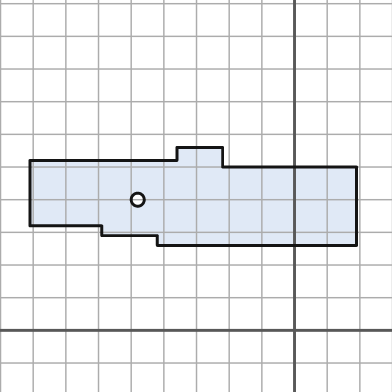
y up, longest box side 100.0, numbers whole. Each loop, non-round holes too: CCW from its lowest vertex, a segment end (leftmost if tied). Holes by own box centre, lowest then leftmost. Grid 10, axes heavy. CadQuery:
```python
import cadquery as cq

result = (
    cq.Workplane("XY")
    .moveTo(-42.0, 26.0)
    .lineTo(19.0, 26.0)
    .lineTo(19.0, 50.0)
    .lineTo(-22.0, 50.0)
    .lineTo(-22.0, 56.0)
    .lineTo(-36.0, 56.0)
    .lineTo(-36.0, 52.0)
    .lineTo(-81.0, 52.0)
    .lineTo(-81.0, 32.0)
    .lineTo(-59.0, 32.0)
    .lineTo(-59.0, 29.0)
    .lineTo(-42.0, 29.0)
    .close()
    .moveTo(-48.0, 40.0)
    .circle(2.0)
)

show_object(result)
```